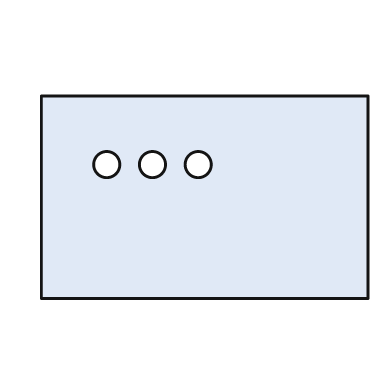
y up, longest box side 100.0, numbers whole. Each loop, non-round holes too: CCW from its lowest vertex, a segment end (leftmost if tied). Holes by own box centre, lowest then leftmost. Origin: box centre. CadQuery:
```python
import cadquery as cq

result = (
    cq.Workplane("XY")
    .moveTo(-50.0, -31.0)
    .lineTo(50.0, -31.0)
    .lineTo(50.0, 31.0)
    .lineTo(-50.0, 31.0)
    .close()
    .moveTo(-30.0, 10.0)
    .circle(4.0)
    .moveTo(-16.0, 10.0)
    .circle(4.0)
    .moveTo(-2.0, 10.0)
    .circle(4.0)
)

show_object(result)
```